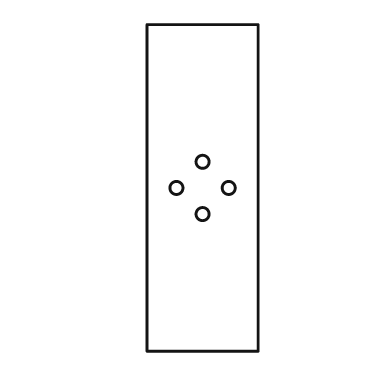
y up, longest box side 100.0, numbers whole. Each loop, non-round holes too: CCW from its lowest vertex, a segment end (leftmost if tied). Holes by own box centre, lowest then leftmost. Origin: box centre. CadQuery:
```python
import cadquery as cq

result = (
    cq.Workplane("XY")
    .moveTo(-17.0, -50.0)
    .lineTo(17.0, -50.0)
    .lineTo(17.0, 50.0)
    .lineTo(-17.0, 50.0)
    .close()
    .moveTo(0.0, -8.0)
    .circle(2.0)
    .moveTo(-8.0, 0.0)
    .circle(2.0)
    .moveTo(8.0, 0.0)
    .circle(2.0)
    .moveTo(0.0, 8.0)
    .circle(2.0)
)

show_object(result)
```